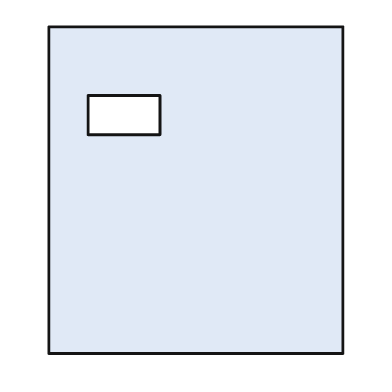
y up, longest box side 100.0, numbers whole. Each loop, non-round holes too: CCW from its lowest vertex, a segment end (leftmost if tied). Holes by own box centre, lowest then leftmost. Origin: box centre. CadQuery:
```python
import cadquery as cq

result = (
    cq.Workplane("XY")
    .moveTo(-45.0, -50.0)
    .lineTo(45.0, -50.0)
    .lineTo(45.0, 50.0)
    .lineTo(-45.0, 50.0)
    .close()
    .moveTo(-33.0, 17.0)
    .lineTo(-11.0, 17.0)
    .lineTo(-11.0, 29.0)
    .lineTo(-33.0, 29.0)
    .close()
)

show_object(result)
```